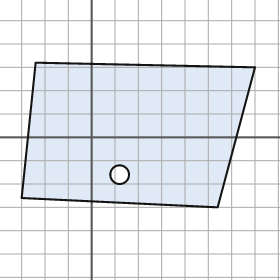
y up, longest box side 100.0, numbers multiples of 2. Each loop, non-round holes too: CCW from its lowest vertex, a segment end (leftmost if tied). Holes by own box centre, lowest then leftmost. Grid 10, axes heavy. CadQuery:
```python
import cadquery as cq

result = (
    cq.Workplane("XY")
    .moveTo(54.0, -30.0)
    .lineTo(70.0, 30.0)
    .lineTo(-24.0, 32.0)
    .lineTo(-30.0, -26.0)
    .close()
    .moveTo(12.0, -16.0)
    .circle(4.0)
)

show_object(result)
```